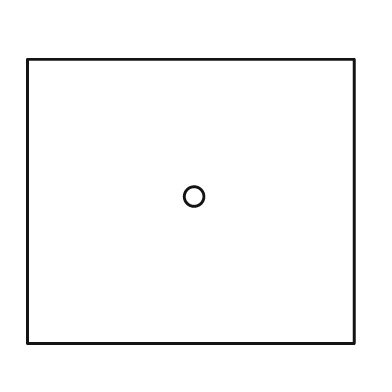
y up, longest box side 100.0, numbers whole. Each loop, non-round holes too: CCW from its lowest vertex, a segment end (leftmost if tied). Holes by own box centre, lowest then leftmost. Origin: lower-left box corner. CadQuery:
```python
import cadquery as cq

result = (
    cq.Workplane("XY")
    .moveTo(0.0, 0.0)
    .lineTo(100.0, 0.0)
    .lineTo(100.0, 87.0)
    .lineTo(0.0, 87.0)
    .close()
    .moveTo(51.0, 45.0)
    .circle(3.0)
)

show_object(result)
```